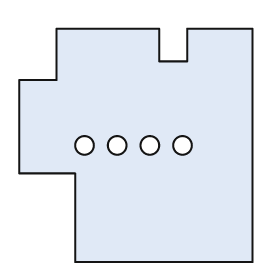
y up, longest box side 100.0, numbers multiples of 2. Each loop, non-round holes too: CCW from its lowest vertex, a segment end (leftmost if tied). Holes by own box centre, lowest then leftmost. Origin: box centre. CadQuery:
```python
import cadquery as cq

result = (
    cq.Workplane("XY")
    .moveTo(-26.0, -50.0)
    .lineTo(50.0, -50.0)
    .lineTo(50.0, 50.0)
    .lineTo(22.0, 50.0)
    .lineTo(22.0, 36.0)
    .lineTo(10.0, 36.0)
    .lineTo(10.0, 50.0)
    .lineTo(-34.0, 50.0)
    .lineTo(-34.0, 28.0)
    .lineTo(-50.0, 28.0)
    .lineTo(-50.0, -12.0)
    .lineTo(-26.0, -12.0)
    .close()
    .moveTo(-22.0, 0.0)
    .circle(4.0)
    .moveTo(-8.0, 0.0)
    .circle(4.0)
    .moveTo(6.0, 0.0)
    .circle(4.0)
    .moveTo(20.0, 0.0)
    .circle(4.0)
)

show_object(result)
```